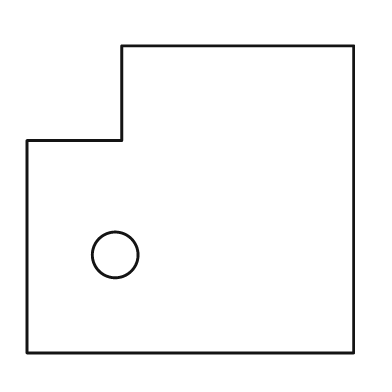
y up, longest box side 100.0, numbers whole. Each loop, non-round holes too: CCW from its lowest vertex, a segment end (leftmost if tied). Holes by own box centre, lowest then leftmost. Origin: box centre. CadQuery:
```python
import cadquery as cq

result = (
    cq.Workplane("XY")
    .moveTo(-50.0, -47.0)
    .lineTo(50.0, -47.0)
    .lineTo(50.0, 47.0)
    .lineTo(-21.0, 47.0)
    .lineTo(-21.0, 18.0)
    .lineTo(-50.0, 18.0)
    .close()
    .moveTo(-23.0, -17.0)
    .circle(7.0)
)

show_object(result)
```